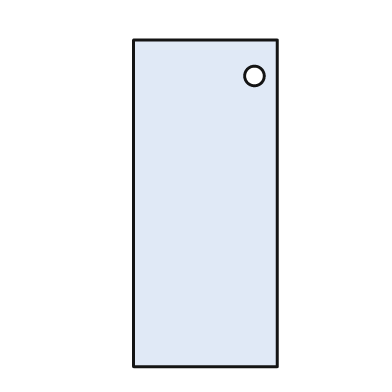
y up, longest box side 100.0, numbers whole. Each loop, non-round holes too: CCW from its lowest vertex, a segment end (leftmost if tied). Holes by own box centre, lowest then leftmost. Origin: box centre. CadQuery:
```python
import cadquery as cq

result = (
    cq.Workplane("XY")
    .moveTo(-22.0, -50.0)
    .lineTo(22.0, -50.0)
    .lineTo(22.0, 50.0)
    .lineTo(-22.0, 50.0)
    .close()
    .moveTo(15.0, 39.0)
    .circle(3.0)
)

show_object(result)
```